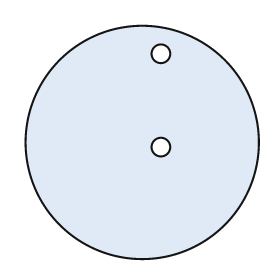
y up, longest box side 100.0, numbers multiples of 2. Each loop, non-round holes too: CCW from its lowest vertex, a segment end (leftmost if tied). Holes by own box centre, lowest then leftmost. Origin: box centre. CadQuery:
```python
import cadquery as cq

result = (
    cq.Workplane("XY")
    .moveTo(0.0, 0.0)
    .circle(50.0)
    .moveTo(8.0, -2.0)
    .circle(4.0)
    .moveTo(8.0, 38.0)
    .circle(4.0)
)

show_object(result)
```